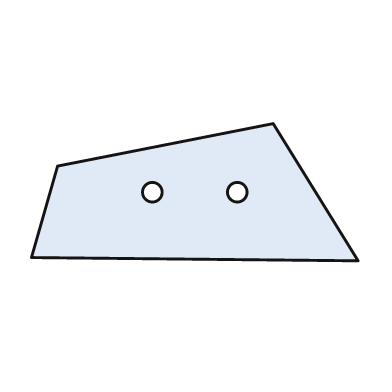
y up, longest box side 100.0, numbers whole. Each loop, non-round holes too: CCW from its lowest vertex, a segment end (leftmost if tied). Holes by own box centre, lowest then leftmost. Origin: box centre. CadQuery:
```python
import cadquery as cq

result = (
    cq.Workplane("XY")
    .moveTo(50.0, -21.0)
    .lineTo(24.0, 21.0)
    .lineTo(-42.0, 8.0)
    .lineTo(-50.0, -20.0)
    .close()
    .moveTo(-13.0, 0.0)
    .circle(3.0)
    .moveTo(13.0, 0.0)
    .circle(3.0)
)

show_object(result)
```